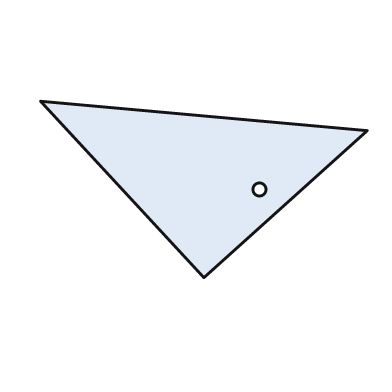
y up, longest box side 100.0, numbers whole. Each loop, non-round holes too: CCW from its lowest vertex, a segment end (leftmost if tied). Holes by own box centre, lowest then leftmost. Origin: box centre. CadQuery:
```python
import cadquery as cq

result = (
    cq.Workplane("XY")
    .moveTo(0.0, -27.0)
    .lineTo(50.0, 18.0)
    .lineTo(-50.0, 27.0)
    .close()
    .moveTo(17.0, 0.0)
    .circle(2.0)
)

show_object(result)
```